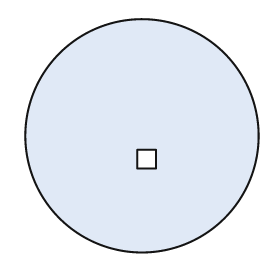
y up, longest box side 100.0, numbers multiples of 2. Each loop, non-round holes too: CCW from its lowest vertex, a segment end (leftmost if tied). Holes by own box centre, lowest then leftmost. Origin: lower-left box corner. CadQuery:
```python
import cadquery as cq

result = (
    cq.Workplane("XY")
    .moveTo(50.0, 50.0)
    .circle(50.0)
    .moveTo(48.0, 36.0)
    .lineTo(56.0, 36.0)
    .lineTo(56.0, 44.0)
    .lineTo(48.0, 44.0)
    .close()
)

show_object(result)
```